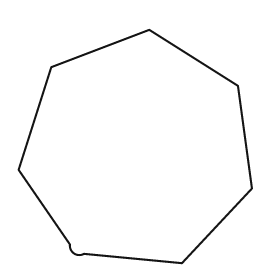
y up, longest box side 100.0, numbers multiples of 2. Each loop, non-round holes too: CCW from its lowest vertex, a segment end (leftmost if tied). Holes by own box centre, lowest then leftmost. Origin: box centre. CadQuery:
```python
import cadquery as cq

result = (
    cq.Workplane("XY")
    .moveTo(20.0, -50.0)
    .lineTo(50.0, -18.0)
    .lineTo(44.0, 26.0)
    .lineTo(6.0, 50.0)
    .lineTo(-36.0, 34.0)
    .lineTo(-50.0, -10.0)
    .lineTo(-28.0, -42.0)
    .threePointArc((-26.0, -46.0), (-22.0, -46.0))
    .close()
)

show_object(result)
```